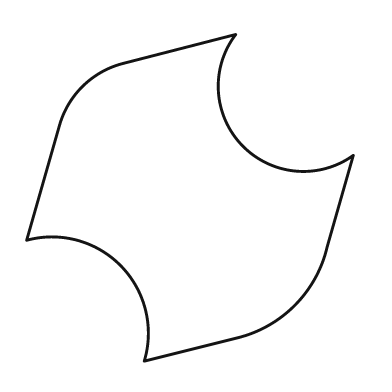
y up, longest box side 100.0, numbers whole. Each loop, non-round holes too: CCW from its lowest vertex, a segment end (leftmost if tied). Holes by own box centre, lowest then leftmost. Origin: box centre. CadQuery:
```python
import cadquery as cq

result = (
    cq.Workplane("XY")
    .moveTo(-14.0, -50.0)
    .lineTo(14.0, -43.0)
    .threePointArc((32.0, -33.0), (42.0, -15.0))
    .lineTo(50.0, 13.0)
    .threePointArc((16.0, 16.0), (14.0, 50.0))
    .lineTo(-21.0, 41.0)
    .threePointArc((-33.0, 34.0), (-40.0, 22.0))
    .lineTo(-50.0, -13.0)
    .threePointArc((-21.0, -21.0), (-14.0, -50.0))
    .close()
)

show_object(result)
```